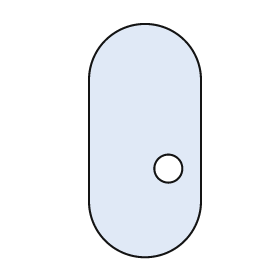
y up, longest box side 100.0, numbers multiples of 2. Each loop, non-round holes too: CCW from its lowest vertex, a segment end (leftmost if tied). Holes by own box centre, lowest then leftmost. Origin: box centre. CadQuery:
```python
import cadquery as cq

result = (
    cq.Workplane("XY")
    .moveTo(-24.0, -26.0)
    .threePointArc((0.0, -50.0), (24.0, -26.0))
    .lineTo(24.0, 26.0)
    .threePointArc((0.0, 50.0), (-24.0, 26.0))
    .close()
    .moveTo(10.0, -12.0)
    .circle(6.0)
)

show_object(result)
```